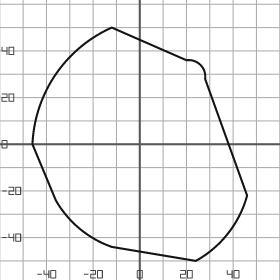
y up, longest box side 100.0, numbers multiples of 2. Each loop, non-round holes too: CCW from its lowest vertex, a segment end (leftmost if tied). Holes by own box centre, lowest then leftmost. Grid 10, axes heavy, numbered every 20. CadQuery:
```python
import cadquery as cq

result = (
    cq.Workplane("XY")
    .moveTo(24.0, -50.0)
    .threePointArc((38.0, -38.0), (46.0, -22.0))
    .lineTo(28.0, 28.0)
    .threePointArc((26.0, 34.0), (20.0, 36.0))
    .lineTo(-12.0, 50.0)
    .threePointArc((-36.0, 30.0), (-46.0, 0.0))
    .lineTo(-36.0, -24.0)
    .threePointArc((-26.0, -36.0), (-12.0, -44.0))
    .close()
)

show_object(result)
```